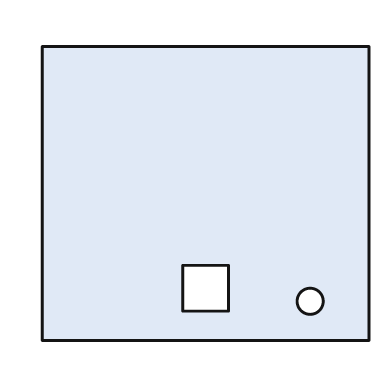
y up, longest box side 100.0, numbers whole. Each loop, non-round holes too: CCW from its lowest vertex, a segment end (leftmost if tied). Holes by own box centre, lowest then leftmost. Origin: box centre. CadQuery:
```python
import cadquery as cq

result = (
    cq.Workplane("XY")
    .moveTo(-50.0, -45.0)
    .lineTo(50.0, -45.0)
    .lineTo(50.0, 45.0)
    .lineTo(-50.0, 45.0)
    .close()
    .moveTo(32.0, -33.0)
    .circle(4.0)
    .moveTo(-7.0, -36.0)
    .lineTo(7.0, -36.0)
    .lineTo(7.0, -22.0)
    .lineTo(-7.0, -22.0)
    .close()
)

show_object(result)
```